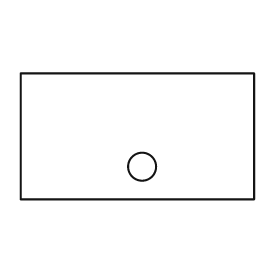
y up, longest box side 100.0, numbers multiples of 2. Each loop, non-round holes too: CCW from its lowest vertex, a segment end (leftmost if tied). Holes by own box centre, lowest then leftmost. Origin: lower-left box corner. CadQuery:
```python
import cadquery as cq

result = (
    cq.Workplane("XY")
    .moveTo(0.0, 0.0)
    .lineTo(100.0, 0.0)
    .lineTo(100.0, 54.0)
    .lineTo(0.0, 54.0)
    .close()
    .moveTo(52.0, 14.0)
    .circle(6.0)
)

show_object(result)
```